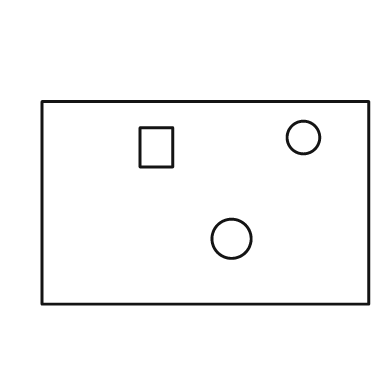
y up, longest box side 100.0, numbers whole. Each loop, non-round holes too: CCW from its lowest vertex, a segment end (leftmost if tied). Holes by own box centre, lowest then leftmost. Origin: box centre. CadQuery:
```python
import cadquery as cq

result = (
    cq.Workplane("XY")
    .moveTo(-50.0, -31.0)
    .lineTo(50.0, -31.0)
    .lineTo(50.0, 31.0)
    .lineTo(-50.0, 31.0)
    .close()
    .moveTo(8.0, -11.0)
    .circle(6.0)
    .moveTo(-20.0, 11.0)
    .lineTo(-10.0, 11.0)
    .lineTo(-10.0, 23.0)
    .lineTo(-20.0, 23.0)
    .close()
    .moveTo(30.0, 20.0)
    .circle(5.0)
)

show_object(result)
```